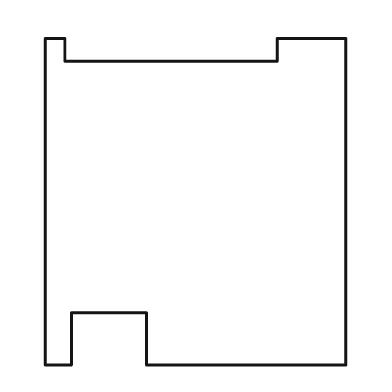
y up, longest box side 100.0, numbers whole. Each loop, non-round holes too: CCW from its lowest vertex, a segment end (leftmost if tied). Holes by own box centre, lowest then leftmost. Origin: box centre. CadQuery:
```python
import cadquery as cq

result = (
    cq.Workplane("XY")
    .moveTo(-46.0, -50.0)
    .lineTo(-38.0, -50.0)
    .lineTo(-38.0, -34.0)
    .lineTo(-15.0, -34.0)
    .lineTo(-15.0, -50.0)
    .lineTo(46.0, -50.0)
    .lineTo(46.0, 50.0)
    .lineTo(25.0, 50.0)
    .lineTo(25.0, 43.0)
    .lineTo(-40.0, 43.0)
    .lineTo(-40.0, 50.0)
    .lineTo(-46.0, 50.0)
    .close()
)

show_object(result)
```